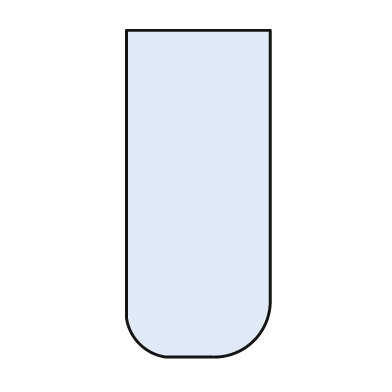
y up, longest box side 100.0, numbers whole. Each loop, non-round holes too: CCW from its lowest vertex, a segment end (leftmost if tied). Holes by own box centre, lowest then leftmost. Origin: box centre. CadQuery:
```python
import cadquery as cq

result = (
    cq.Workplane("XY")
    .moveTo(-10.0, -50.0)
    .lineTo(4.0, -50.0)
    .threePointArc((17.0, -45.0), (22.0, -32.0))
    .lineTo(22.0, 50.0)
    .lineTo(-22.0, 50.0)
    .lineTo(-22.0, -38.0)
    .threePointArc((-18.0, -46.0), (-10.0, -50.0))
    .close()
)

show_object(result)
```